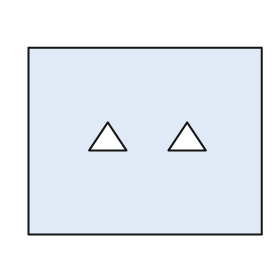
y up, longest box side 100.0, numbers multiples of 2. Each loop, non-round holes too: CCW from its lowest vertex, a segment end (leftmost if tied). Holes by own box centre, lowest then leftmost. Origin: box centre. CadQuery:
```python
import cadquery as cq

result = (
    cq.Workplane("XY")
    .moveTo(-50.0, -40.0)
    .lineTo(50.0, -40.0)
    .lineTo(50.0, 40.0)
    .lineTo(-50.0, 40.0)
    .close()
    .moveTo(-24.0, -4.0)
    .lineTo(-8.0, -4.0)
    .lineTo(-16.0, 8.0)
    .close()
    .moveTo(10.0, -4.0)
    .lineTo(26.0, -4.0)
    .lineTo(18.0, 8.0)
    .close()
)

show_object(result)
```